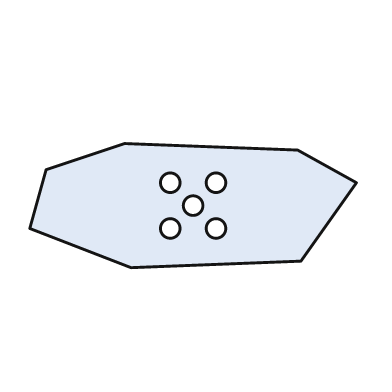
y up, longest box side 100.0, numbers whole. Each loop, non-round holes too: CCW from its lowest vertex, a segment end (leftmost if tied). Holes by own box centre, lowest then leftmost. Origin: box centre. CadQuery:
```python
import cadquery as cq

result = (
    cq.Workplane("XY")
    .moveTo(-19.0, -19.0)
    .lineTo(33.0, -17.0)
    .lineTo(50.0, 7.0)
    .lineTo(32.0, 17.0)
    .lineTo(-21.0, 19.0)
    .lineTo(-45.0, 11.0)
    .lineTo(-50.0, -7.0)
    .close()
    .moveTo(-7.0, -7.0)
    .circle(3.0)
    .moveTo(7.0, -7.0)
    .circle(3.0)
    .moveTo(0.0, 0.0)
    .circle(3.0)
    .moveTo(-7.0, 7.0)
    .circle(3.0)
    .moveTo(7.0, 7.0)
    .circle(3.0)
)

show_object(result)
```